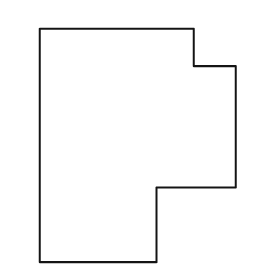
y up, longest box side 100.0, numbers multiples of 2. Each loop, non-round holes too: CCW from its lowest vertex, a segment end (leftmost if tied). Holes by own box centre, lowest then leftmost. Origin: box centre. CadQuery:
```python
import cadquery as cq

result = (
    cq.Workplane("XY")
    .moveTo(-42.0, -50.0)
    .lineTo(8.0, -50.0)
    .lineTo(8.0, -18.0)
    .lineTo(42.0, -18.0)
    .lineTo(42.0, 34.0)
    .lineTo(24.0, 34.0)
    .lineTo(24.0, 50.0)
    .lineTo(-42.0, 50.0)
    .close()
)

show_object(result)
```